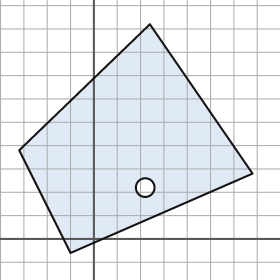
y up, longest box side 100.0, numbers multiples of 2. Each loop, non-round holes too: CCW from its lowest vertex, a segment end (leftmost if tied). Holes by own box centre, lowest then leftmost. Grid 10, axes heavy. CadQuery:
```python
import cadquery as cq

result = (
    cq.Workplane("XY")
    .moveTo(-10.0, -6.0)
    .lineTo(68.0, 28.0)
    .lineTo(24.0, 92.0)
    .lineTo(-32.0, 38.0)
    .close()
    .moveTo(22.0, 22.0)
    .circle(4.0)
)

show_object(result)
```